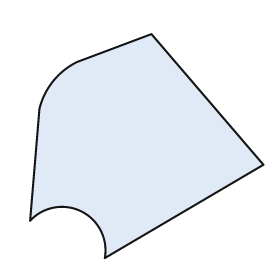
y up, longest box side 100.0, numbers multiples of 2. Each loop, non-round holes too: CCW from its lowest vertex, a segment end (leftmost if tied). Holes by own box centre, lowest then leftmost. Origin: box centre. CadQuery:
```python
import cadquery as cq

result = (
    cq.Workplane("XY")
    .moveTo(-18.0, -48.0)
    .lineTo(50.0, -8.0)
    .lineTo(2.0, 48.0)
    .lineTo(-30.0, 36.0)
    .threePointArc((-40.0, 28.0), (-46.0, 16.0))
    .lineTo(-50.0, -32.0)
    .threePointArc((-28.0, -28.0), (-18.0, -48.0))
    .close()
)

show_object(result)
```